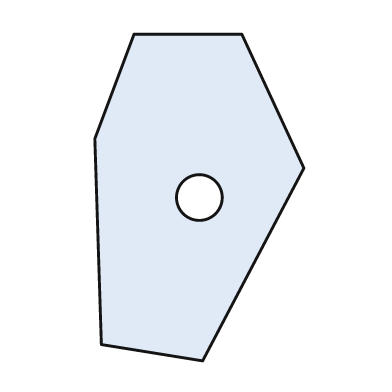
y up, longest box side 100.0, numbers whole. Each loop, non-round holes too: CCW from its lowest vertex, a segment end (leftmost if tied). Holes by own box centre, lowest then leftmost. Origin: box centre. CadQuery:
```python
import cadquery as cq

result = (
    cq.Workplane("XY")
    .moveTo(1.0, -50.0)
    .lineTo(32.0, 9.0)
    .lineTo(13.0, 50.0)
    .lineTo(-20.0, 50.0)
    .lineTo(-32.0, 18.0)
    .lineTo(-30.0, -45.0)
    .close()
    .moveTo(0.0, 0.0)
    .circle(7.0)
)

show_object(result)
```